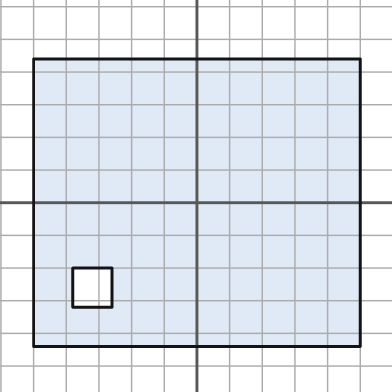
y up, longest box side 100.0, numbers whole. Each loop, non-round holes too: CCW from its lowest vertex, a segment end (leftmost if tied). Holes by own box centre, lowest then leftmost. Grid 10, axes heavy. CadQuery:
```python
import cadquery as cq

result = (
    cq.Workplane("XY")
    .moveTo(-50.0, -44.0)
    .lineTo(50.0, -44.0)
    .lineTo(50.0, 44.0)
    .lineTo(-50.0, 44.0)
    .close()
    .moveTo(-38.0, -32.0)
    .lineTo(-26.0, -32.0)
    .lineTo(-26.0, -20.0)
    .lineTo(-38.0, -20.0)
    .close()
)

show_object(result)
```